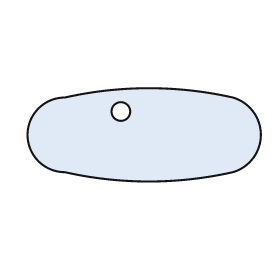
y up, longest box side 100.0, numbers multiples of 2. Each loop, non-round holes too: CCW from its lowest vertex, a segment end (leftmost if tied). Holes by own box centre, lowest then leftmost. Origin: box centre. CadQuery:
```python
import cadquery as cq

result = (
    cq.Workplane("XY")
    .moveTo(-34.0, -16.0)
    .threePointArc((2.0, -20.0), (38.0, -16.0))
    .threePointArc((50.0, 0.0), (38.0, 16.0))
    .threePointArc((2.0, 20.0), (-34.0, 16.0))
    .threePointArc((-50.0, 0.0), (-34.0, -16.0))
    .close()
    .moveTo(-10.0, 10.0)
    .circle(4.0)
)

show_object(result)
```